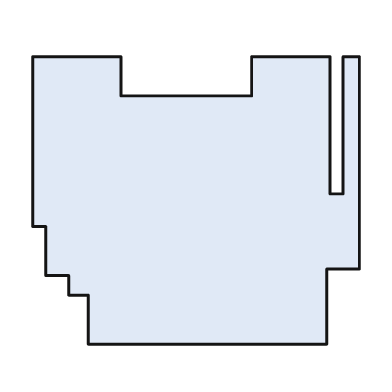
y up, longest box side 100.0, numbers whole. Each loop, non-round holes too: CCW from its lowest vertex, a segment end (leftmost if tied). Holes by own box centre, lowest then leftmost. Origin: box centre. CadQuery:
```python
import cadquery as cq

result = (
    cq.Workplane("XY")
    .moveTo(-33.0, -44.0)
    .lineTo(40.0, -44.0)
    .lineTo(40.0, -21.0)
    .lineTo(50.0, -21.0)
    .lineTo(50.0, 44.0)
    .lineTo(45.0, 44.0)
    .lineTo(45.0, 2.0)
    .lineTo(41.0, 2.0)
    .lineTo(41.0, 44.0)
    .lineTo(17.0, 44.0)
    .lineTo(17.0, 32.0)
    .lineTo(-23.0, 32.0)
    .lineTo(-23.0, 44.0)
    .lineTo(-50.0, 44.0)
    .lineTo(-50.0, -8.0)
    .lineTo(-46.0, -8.0)
    .lineTo(-46.0, -23.0)
    .lineTo(-39.0, -23.0)
    .lineTo(-39.0, -29.0)
    .lineTo(-33.0, -29.0)
    .close()
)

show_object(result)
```